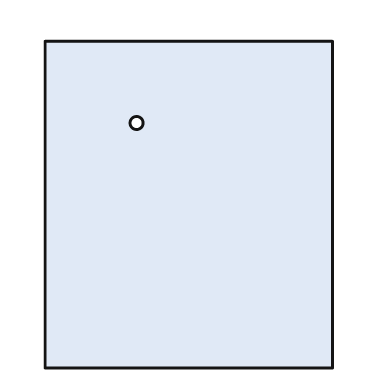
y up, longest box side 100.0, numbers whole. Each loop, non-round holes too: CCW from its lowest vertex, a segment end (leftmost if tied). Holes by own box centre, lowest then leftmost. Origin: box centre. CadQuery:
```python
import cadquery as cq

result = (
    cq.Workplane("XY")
    .moveTo(-44.0, -50.0)
    .lineTo(44.0, -50.0)
    .lineTo(44.0, 50.0)
    .lineTo(-44.0, 50.0)
    .close()
    .moveTo(-16.0, 25.0)
    .circle(2.0)
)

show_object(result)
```